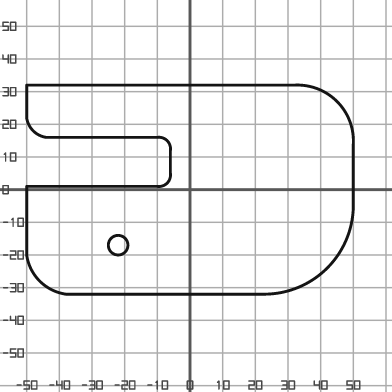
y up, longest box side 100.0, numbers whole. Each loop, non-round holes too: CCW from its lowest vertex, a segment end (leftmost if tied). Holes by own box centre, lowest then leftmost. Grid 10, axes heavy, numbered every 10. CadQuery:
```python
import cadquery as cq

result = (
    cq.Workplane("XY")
    .moveTo(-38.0, -32.0)
    .lineTo(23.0, -32.0)
    .threePointArc((42.0, -24.0), (50.0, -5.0))
    .lineTo(50.0, 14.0)
    .threePointArc((45.0, 27.0), (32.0, 32.0))
    .lineTo(-50.0, 32.0)
    .lineTo(-50.0, 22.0)
    .threePointArc((-48.0, 18.0), (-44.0, 16.0))
    .lineTo(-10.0, 16.0)
    .threePointArc((-7.0, 15.0), (-6.0, 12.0))
    .lineTo(-6.0, 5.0)
    .threePointArc((-7.0, 2.0), (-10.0, 1.0))
    .lineTo(-50.0, 1.0)
    .lineTo(-50.0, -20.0)
    .threePointArc((-46.0, -28.0), (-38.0, -32.0))
    .close()
    .moveTo(-22.0, -17.0)
    .circle(3.0)
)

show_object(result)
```